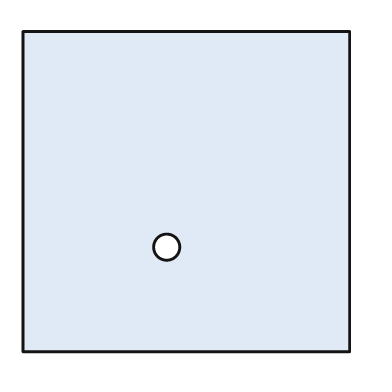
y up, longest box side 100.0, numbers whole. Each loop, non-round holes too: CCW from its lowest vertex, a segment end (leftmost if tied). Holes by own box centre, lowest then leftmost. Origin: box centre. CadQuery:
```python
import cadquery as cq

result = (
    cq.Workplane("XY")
    .moveTo(-50.0, -49.0)
    .lineTo(50.0, -49.0)
    .lineTo(50.0, 49.0)
    .lineTo(-50.0, 49.0)
    .close()
    .moveTo(-6.0, -17.0)
    .circle(4.0)
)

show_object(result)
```